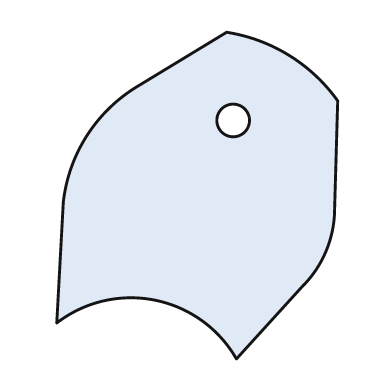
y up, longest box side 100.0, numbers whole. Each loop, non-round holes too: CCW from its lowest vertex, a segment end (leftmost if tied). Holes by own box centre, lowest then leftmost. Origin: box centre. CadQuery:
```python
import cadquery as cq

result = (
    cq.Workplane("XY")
    .moveTo(12.0, -50.0)
    .lineTo(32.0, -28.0)
    .threePointArc((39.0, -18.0), (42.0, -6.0))
    .lineTo(43.0, 29.0)
    .threePointArc((28.0, 43.0), (9.0, 50.0))
    .lineTo(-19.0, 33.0)
    .threePointArc((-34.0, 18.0), (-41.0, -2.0))
    .lineTo(-43.0, -39.0)
    .threePointArc((-13.0, -32.0), (12.0, -50.0))
    .close()
    .moveTo(11.0, 23.0)
    .circle(5.0)
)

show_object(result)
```